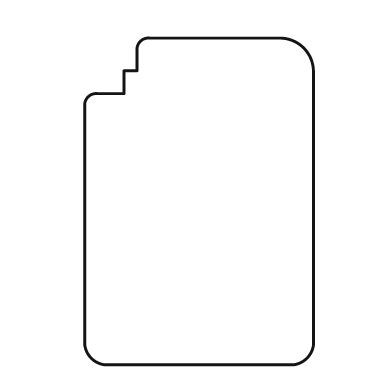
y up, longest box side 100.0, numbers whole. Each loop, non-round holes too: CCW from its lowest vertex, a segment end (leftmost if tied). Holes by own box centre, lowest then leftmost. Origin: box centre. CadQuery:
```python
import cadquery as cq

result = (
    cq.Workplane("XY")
    .moveTo(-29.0, -50.0)
    .lineTo(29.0, -50.0)
    .threePointArc((33.0, -48.0), (35.0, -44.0))
    .lineTo(35.0, 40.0)
    .threePointArc((32.0, 47.0), (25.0, 50.0))
    .lineTo(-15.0, 50.0)
    .threePointArc((-18.0, 49.0), (-19.0, 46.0))
    .lineTo(-19.0, 40.0)
    .lineTo(-23.0, 40.0)
    .lineTo(-23.0, 33.0)
    .lineTo(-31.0, 33.0)
    .threePointArc((-34.0, 32.0), (-35.0, 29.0))
    .lineTo(-35.0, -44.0)
    .threePointArc((-33.0, -48.0), (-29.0, -50.0))
    .close()
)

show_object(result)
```